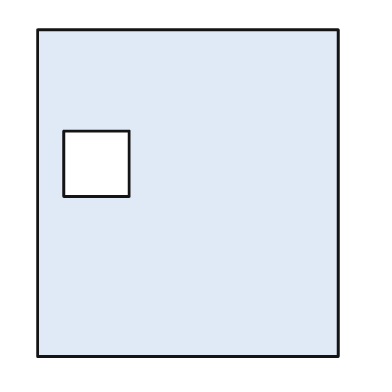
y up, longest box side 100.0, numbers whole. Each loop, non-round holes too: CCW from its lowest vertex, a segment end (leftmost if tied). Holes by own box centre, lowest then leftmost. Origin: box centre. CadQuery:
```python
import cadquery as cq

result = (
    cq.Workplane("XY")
    .moveTo(-46.0, -50.0)
    .lineTo(46.0, -50.0)
    .lineTo(46.0, 50.0)
    .lineTo(-46.0, 50.0)
    .close()
    .moveTo(-38.0, -1.0)
    .lineTo(-18.0, -1.0)
    .lineTo(-18.0, 19.0)
    .lineTo(-38.0, 19.0)
    .close()
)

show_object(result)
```